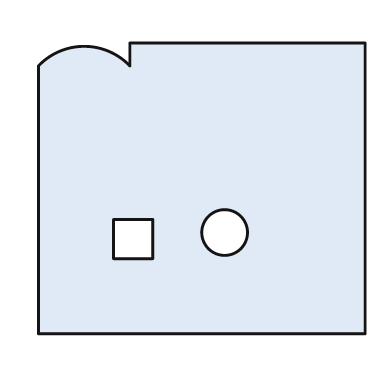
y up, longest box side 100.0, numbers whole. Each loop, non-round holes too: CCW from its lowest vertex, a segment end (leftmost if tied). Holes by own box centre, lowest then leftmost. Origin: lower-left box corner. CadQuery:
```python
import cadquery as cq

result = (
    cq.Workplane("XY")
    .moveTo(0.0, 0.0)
    .lineTo(100.0, 0.0)
    .lineTo(100.0, 89.0)
    .lineTo(28.0, 89.0)
    .lineTo(28.0, 82.0)
    .threePointArc((14.0, 88.0), (0.0, 82.0))
    .close()
    .moveTo(23.0, 23.0)
    .lineTo(35.0, 23.0)
    .lineTo(35.0, 35.0)
    .lineTo(23.0, 35.0)
    .close()
    .moveTo(57.0, 31.0)
    .circle(7.0)
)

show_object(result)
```